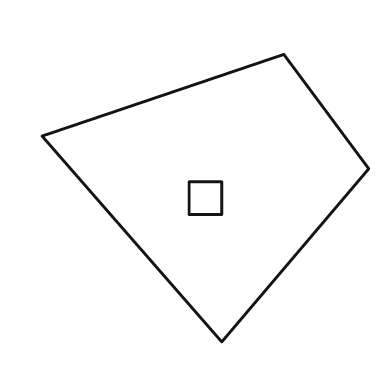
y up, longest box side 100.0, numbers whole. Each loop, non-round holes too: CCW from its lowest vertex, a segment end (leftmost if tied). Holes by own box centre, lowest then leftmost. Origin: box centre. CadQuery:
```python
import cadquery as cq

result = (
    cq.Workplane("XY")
    .moveTo(5.0, -44.0)
    .lineTo(50.0, 9.0)
    .lineTo(24.0, 44.0)
    .lineTo(-50.0, 19.0)
    .close()
    .moveTo(-5.0, -5.0)
    .lineTo(5.0, -5.0)
    .lineTo(5.0, 5.0)
    .lineTo(-5.0, 5.0)
    .close()
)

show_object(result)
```